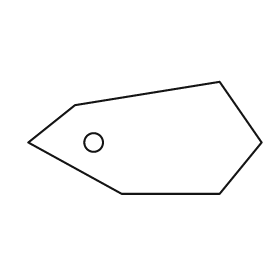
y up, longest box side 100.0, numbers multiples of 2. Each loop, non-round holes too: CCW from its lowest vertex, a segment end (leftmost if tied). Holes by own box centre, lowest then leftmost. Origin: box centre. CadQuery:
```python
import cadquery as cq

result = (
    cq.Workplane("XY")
    .moveTo(-10.0, -24.0)
    .lineTo(32.0, -24.0)
    .lineTo(50.0, -2.0)
    .lineTo(32.0, 24.0)
    .lineTo(-30.0, 14.0)
    .lineTo(-50.0, -2.0)
    .close()
    .moveTo(-22.0, -2.0)
    .circle(4.0)
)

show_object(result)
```